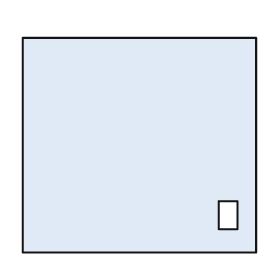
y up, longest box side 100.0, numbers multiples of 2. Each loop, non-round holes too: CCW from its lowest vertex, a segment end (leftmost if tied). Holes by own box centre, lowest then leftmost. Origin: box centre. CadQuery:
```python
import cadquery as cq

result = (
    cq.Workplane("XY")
    .moveTo(-50.0, -46.0)
    .lineTo(50.0, -46.0)
    .lineTo(50.0, 46.0)
    .lineTo(-50.0, 46.0)
    .close()
    .moveTo(34.0, -36.0)
    .lineTo(42.0, -36.0)
    .lineTo(42.0, -24.0)
    .lineTo(34.0, -24.0)
    .close()
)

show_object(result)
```